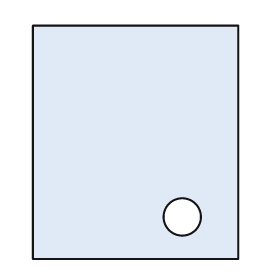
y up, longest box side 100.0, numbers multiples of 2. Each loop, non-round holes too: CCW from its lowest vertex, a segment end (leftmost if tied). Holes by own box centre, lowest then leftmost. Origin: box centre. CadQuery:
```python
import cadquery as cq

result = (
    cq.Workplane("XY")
    .moveTo(-44.0, -50.0)
    .lineTo(44.0, -50.0)
    .lineTo(44.0, 50.0)
    .lineTo(-44.0, 50.0)
    .close()
    .moveTo(20.0, -32.0)
    .circle(8.0)
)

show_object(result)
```